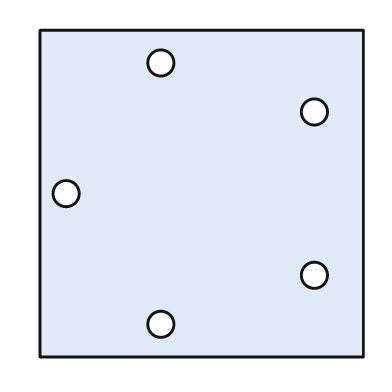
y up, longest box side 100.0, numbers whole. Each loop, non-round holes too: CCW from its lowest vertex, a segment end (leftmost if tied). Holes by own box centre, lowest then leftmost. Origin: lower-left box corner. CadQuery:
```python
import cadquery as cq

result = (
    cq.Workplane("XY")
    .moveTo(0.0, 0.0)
    .lineTo(99.0, 0.0)
    .lineTo(99.0, 100.0)
    .lineTo(0.0, 100.0)
    .close()
    .moveTo(37.0, 10.0)
    .circle(4.0)
    .moveTo(84.0, 25.0)
    .circle(4.0)
    .moveTo(8.0, 50.0)
    .circle(4.0)
    .moveTo(84.0, 75.0)
    .circle(4.0)
    .moveTo(37.0, 90.0)
    .circle(4.0)
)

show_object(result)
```